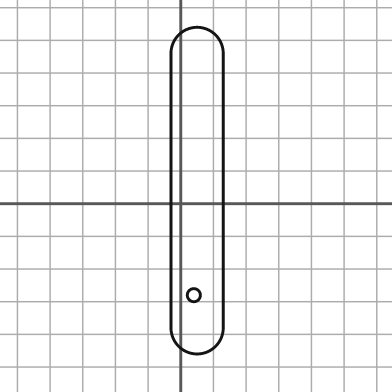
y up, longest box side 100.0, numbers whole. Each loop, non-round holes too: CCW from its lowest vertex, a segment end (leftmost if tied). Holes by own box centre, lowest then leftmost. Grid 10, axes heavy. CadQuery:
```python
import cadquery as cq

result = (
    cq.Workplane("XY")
    .moveTo(-3.0, -38.0)
    .threePointArc((5.0, -46.0), (13.0, -38.0))
    .lineTo(13.0, 46.0)
    .threePointArc((5.0, 54.0), (-3.0, 46.0))
    .close()
    .moveTo(4.0, -28.0)
    .circle(2.0)
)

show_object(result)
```